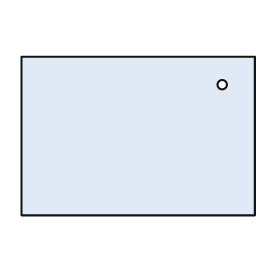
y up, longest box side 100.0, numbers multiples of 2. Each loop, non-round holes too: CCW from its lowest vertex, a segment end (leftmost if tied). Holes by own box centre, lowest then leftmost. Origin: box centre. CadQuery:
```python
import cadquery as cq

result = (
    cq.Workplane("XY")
    .moveTo(-50.0, -34.0)
    .lineTo(50.0, -34.0)
    .lineTo(50.0, 34.0)
    .lineTo(-50.0, 34.0)
    .close()
    .moveTo(36.0, 22.0)
    .circle(2.0)
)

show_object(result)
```